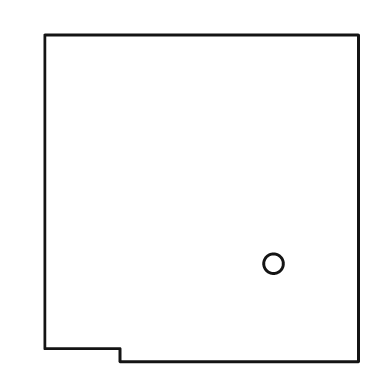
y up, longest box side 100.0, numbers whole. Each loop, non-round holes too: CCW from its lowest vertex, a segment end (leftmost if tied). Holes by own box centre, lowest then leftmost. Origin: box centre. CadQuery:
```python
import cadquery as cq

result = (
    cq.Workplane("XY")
    .moveTo(-25.0, -50.0)
    .lineTo(48.0, -50.0)
    .lineTo(48.0, 50.0)
    .lineTo(-48.0, 50.0)
    .lineTo(-48.0, -46.0)
    .lineTo(-25.0, -46.0)
    .close()
    .moveTo(22.0, -20.0)
    .circle(3.0)
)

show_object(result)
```